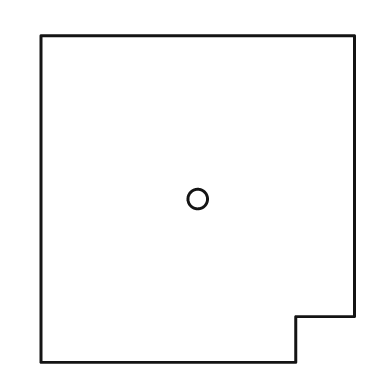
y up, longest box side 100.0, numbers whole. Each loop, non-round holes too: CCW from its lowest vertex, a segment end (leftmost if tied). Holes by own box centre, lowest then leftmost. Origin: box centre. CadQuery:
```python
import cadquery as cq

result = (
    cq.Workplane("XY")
    .moveTo(-48.0, -50.0)
    .lineTo(30.0, -50.0)
    .lineTo(30.0, -36.0)
    .lineTo(48.0, -36.0)
    .lineTo(48.0, 50.0)
    .lineTo(-48.0, 50.0)
    .close()
    .moveTo(0.0, 0.0)
    .circle(3.0)
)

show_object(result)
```